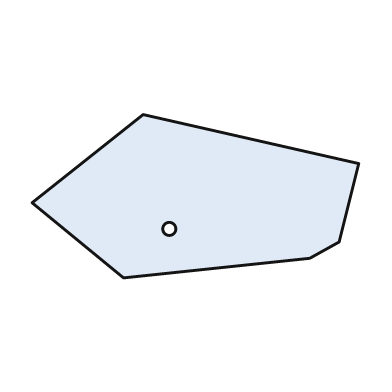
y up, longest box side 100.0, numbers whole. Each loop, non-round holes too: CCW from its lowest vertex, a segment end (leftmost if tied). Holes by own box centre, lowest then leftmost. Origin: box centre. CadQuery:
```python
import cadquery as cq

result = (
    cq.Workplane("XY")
    .moveTo(-22.0, -25.0)
    .lineTo(35.0, -19.0)
    .lineTo(44.0, -14.0)
    .lineTo(50.0, 10.0)
    .lineTo(-16.0, 25.0)
    .lineTo(-50.0, -2.0)
    .close()
    .moveTo(-8.0, -10.0)
    .circle(2.0)
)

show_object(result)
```